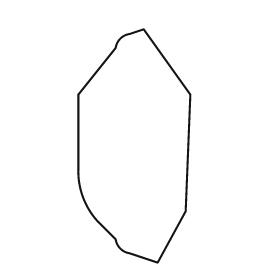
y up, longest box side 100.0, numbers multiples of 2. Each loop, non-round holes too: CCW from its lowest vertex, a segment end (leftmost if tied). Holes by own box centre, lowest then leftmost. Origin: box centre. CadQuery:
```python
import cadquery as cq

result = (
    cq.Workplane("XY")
    .moveTo(10.0, -50.0)
    .lineTo(22.0, -28.0)
    .lineTo(24.0, 22.0)
    .lineTo(4.0, 50.0)
    .lineTo(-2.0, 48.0)
    .threePointArc((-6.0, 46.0), (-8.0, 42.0))
    .lineTo(-24.0, 22.0)
    .lineTo(-24.0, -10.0)
    .threePointArc((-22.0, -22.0), (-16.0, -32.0))
    .lineTo(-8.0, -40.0)
    .threePointArc((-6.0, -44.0), (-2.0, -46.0))
    .close()
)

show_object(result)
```